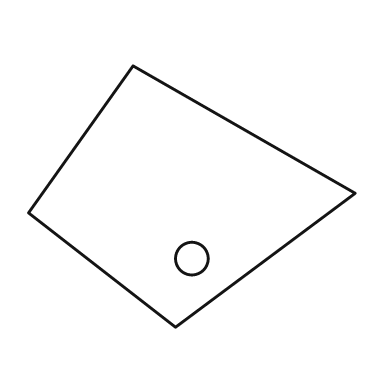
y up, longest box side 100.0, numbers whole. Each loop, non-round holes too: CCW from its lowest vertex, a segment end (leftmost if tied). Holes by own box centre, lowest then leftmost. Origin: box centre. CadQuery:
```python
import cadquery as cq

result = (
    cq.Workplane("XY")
    .moveTo(-5.0, -40.0)
    .lineTo(50.0, 1.0)
    .lineTo(-18.0, 40.0)
    .lineTo(-50.0, -5.0)
    .close()
    .moveTo(0.0, -19.0)
    .circle(5.0)
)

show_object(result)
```